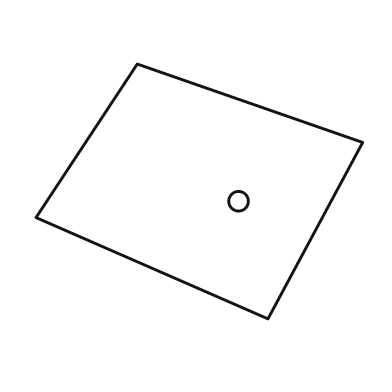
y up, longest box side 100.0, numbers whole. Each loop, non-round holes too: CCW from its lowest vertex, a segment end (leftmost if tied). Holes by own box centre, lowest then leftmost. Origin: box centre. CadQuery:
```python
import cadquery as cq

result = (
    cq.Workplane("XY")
    .moveTo(21.0, -39.0)
    .lineTo(50.0, 15.0)
    .lineTo(-19.0, 39.0)
    .lineTo(-50.0, -8.0)
    .close()
    .moveTo(12.0, -3.0)
    .circle(3.0)
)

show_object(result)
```